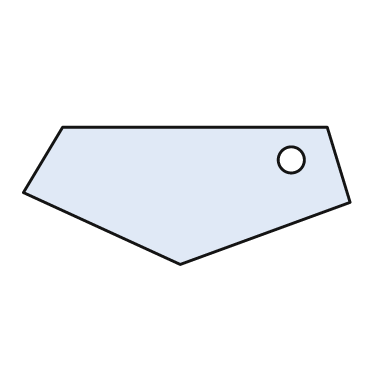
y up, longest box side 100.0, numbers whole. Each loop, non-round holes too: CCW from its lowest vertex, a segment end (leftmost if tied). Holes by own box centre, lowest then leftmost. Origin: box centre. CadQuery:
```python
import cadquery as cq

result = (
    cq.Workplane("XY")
    .moveTo(-2.0, -21.0)
    .lineTo(50.0, -2.0)
    .lineTo(43.0, 21.0)
    .lineTo(-38.0, 21.0)
    .lineTo(-50.0, 1.0)
    .close()
    .moveTo(32.0, 11.0)
    .circle(4.0)
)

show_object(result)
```